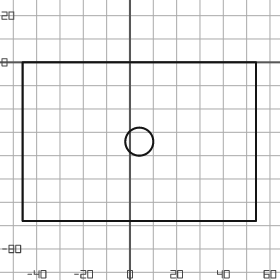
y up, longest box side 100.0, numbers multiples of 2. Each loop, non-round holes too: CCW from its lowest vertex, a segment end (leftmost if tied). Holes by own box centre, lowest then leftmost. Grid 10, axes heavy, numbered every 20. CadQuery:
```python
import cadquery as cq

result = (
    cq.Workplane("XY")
    .moveTo(-46.0, -68.0)
    .lineTo(54.0, -68.0)
    .lineTo(54.0, 0.0)
    .lineTo(-46.0, 0.0)
    .close()
    .moveTo(4.0, -34.0)
    .circle(6.0)
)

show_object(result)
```